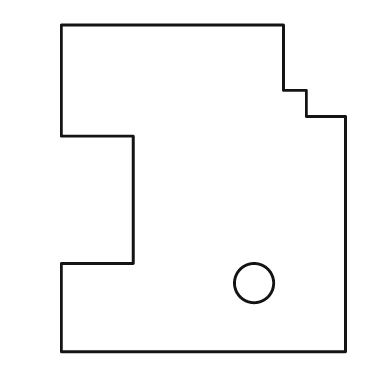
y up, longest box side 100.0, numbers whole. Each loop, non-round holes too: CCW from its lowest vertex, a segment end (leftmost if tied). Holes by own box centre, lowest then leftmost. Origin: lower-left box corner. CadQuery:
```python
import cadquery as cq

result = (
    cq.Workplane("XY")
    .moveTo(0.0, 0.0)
    .lineTo(87.0, 0.0)
    .lineTo(87.0, 72.0)
    .lineTo(75.0, 72.0)
    .lineTo(75.0, 80.0)
    .lineTo(68.0, 80.0)
    .lineTo(68.0, 100.0)
    .lineTo(0.0, 100.0)
    .lineTo(0.0, 66.0)
    .lineTo(22.0, 66.0)
    .lineTo(22.0, 27.0)
    .lineTo(0.0, 27.0)
    .close()
    .moveTo(59.0, 21.0)
    .circle(6.0)
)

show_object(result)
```